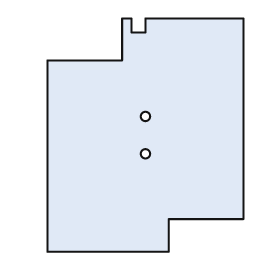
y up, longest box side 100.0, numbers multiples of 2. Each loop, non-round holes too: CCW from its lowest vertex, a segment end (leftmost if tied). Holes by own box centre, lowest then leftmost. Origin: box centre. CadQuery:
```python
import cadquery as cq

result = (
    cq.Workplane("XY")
    .moveTo(-42.0, -50.0)
    .lineTo(10.0, -50.0)
    .lineTo(10.0, -36.0)
    .lineTo(42.0, -36.0)
    .lineTo(42.0, 50.0)
    .lineTo(0.0, 50.0)
    .lineTo(0.0, 44.0)
    .lineTo(-6.0, 44.0)
    .lineTo(-6.0, 50.0)
    .lineTo(-10.0, 50.0)
    .lineTo(-10.0, 32.0)
    .lineTo(-42.0, 32.0)
    .close()
    .moveTo(0.0, -8.0)
    .circle(2.0)
    .moveTo(0.0, 8.0)
    .circle(2.0)
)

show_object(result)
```